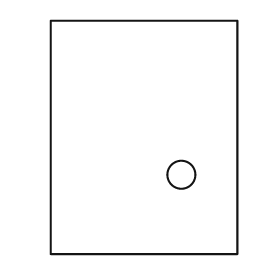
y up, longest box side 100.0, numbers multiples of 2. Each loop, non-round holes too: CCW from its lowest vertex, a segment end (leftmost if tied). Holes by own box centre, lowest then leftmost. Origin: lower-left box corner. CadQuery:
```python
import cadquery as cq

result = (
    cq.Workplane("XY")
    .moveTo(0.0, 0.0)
    .lineTo(80.0, 0.0)
    .lineTo(80.0, 100.0)
    .lineTo(0.0, 100.0)
    .close()
    .moveTo(56.0, 34.0)
    .circle(6.0)
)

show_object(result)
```